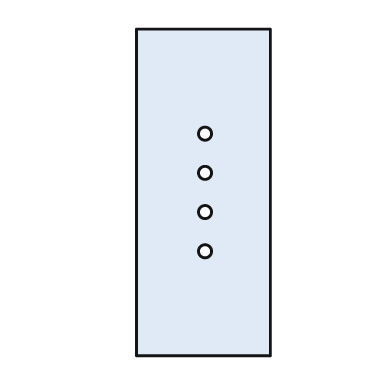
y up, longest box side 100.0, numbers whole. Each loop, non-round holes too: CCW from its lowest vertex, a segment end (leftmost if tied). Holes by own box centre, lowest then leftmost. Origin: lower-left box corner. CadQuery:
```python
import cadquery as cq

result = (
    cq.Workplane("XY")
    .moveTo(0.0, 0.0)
    .lineTo(41.0, 0.0)
    .lineTo(41.0, 100.0)
    .lineTo(0.0, 100.0)
    .close()
    .moveTo(21.0, 32.0)
    .circle(2.0)
    .moveTo(21.0, 44.0)
    .circle(2.0)
    .moveTo(21.0, 56.0)
    .circle(2.0)
    .moveTo(21.0, 68.0)
    .circle(2.0)
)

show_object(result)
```